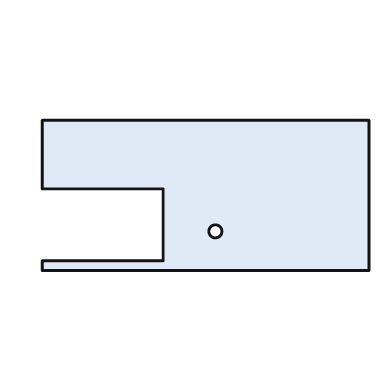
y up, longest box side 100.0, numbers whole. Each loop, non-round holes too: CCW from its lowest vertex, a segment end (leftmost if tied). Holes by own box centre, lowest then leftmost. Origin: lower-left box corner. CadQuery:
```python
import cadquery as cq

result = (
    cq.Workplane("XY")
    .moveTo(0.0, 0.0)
    .lineTo(100.0, 0.0)
    .lineTo(100.0, 46.0)
    .lineTo(0.0, 46.0)
    .lineTo(0.0, 25.0)
    .lineTo(37.0, 25.0)
    .lineTo(37.0, 3.0)
    .lineTo(0.0, 3.0)
    .close()
    .moveTo(53.0, 12.0)
    .circle(2.0)
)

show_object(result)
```